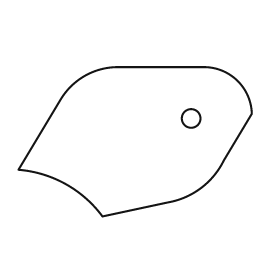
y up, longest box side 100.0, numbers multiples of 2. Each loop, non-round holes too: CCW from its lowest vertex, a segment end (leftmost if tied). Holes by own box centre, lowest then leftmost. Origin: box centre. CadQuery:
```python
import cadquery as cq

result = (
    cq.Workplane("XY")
    .moveTo(-14.0, -32.0)
    .lineTo(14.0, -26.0)
    .threePointArc((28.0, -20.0), (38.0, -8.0))
    .lineTo(50.0, 12.0)
    .threePointArc((44.0, 26.0), (30.0, 32.0))
    .lineTo(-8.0, 32.0)
    .threePointArc((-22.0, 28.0), (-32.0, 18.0))
    .lineTo(-50.0, -12.0)
    .threePointArc((-30.0, -18.0), (-14.0, -32.0))
    .close()
    .moveTo(24.0, 10.0)
    .circle(4.0)
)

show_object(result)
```